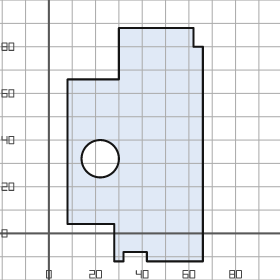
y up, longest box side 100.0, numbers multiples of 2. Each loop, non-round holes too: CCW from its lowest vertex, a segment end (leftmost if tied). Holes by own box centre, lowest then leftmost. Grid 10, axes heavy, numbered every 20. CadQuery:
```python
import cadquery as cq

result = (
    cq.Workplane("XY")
    .moveTo(28.0, -12.0)
    .lineTo(32.0, -12.0)
    .lineTo(32.0, -8.0)
    .lineTo(42.0, -8.0)
    .lineTo(42.0, -12.0)
    .lineTo(66.0, -12.0)
    .lineTo(66.0, 80.0)
    .lineTo(62.0, 80.0)
    .lineTo(62.0, 88.0)
    .lineTo(30.0, 88.0)
    .lineTo(30.0, 66.0)
    .lineTo(8.0, 66.0)
    .lineTo(8.0, 4.0)
    .lineTo(28.0, 4.0)
    .close()
    .moveTo(22.0, 32.0)
    .circle(8.0)
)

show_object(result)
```